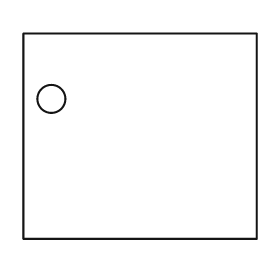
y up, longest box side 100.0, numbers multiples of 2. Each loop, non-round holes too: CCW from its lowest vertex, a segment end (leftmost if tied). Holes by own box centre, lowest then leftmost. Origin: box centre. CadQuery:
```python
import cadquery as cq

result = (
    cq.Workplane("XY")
    .moveTo(-50.0, -44.0)
    .lineTo(50.0, -44.0)
    .lineTo(50.0, 44.0)
    .lineTo(-50.0, 44.0)
    .close()
    .moveTo(-38.0, 16.0)
    .circle(6.0)
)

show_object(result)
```